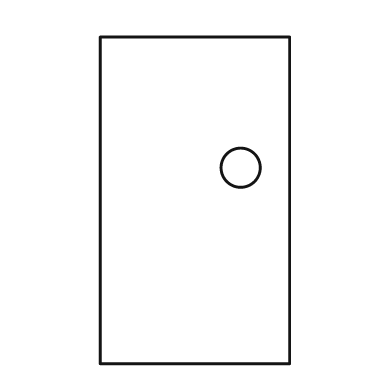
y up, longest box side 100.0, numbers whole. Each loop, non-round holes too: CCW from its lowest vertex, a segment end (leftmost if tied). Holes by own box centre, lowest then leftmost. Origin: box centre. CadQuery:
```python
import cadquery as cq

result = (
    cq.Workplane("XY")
    .moveTo(-29.0, -50.0)
    .lineTo(29.0, -50.0)
    .lineTo(29.0, 50.0)
    .lineTo(-29.0, 50.0)
    .close()
    .moveTo(14.0, 10.0)
    .circle(6.0)
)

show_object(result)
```